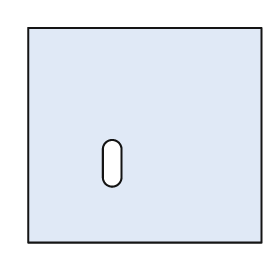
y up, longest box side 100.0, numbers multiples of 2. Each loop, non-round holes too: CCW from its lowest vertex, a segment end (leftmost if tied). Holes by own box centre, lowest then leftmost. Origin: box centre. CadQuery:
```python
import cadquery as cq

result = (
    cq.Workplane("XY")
    .moveTo(-50.0, -46.0)
    .lineTo(50.0, -46.0)
    .lineTo(50.0, 46.0)
    .lineTo(-50.0, 46.0)
    .close()
    .moveTo(-18.0, -18.0)
    .threePointArc((-14.0, -22.0), (-10.0, -18.0))
    .lineTo(-10.0, -6.0)
    .threePointArc((-14.0, -2.0), (-18.0, -6.0))
    .close()
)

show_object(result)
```